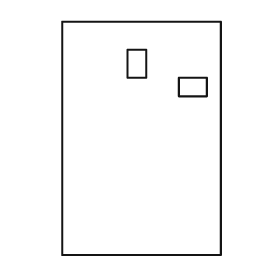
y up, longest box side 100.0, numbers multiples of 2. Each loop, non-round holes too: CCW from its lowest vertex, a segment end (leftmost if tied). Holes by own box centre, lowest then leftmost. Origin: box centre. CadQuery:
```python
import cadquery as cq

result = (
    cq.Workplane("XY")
    .moveTo(-34.0, -50.0)
    .lineTo(34.0, -50.0)
    .lineTo(34.0, 50.0)
    .lineTo(-34.0, 50.0)
    .close()
    .moveTo(16.0, 18.0)
    .lineTo(28.0, 18.0)
    .lineTo(28.0, 26.0)
    .lineTo(16.0, 26.0)
    .close()
    .moveTo(-6.0, 26.0)
    .lineTo(2.0, 26.0)
    .lineTo(2.0, 38.0)
    .lineTo(-6.0, 38.0)
    .close()
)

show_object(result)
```